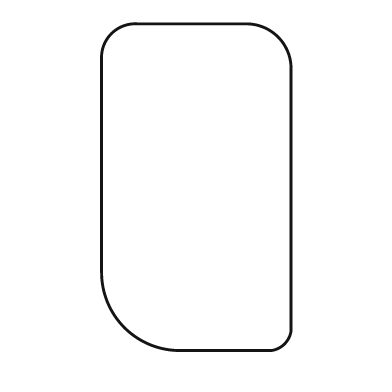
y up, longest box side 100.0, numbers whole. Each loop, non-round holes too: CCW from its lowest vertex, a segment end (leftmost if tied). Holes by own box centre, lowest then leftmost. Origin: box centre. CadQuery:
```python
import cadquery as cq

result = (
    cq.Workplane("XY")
    .moveTo(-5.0, -50.0)
    .lineTo(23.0, -50.0)
    .threePointArc((27.0, -48.0), (29.0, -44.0))
    .lineTo(29.0, 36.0)
    .threePointArc((25.0, 46.0), (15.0, 50.0))
    .lineTo(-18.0, 50.0)
    .threePointArc((-26.0, 47.0), (-29.0, 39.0))
    .lineTo(-29.0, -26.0)
    .threePointArc((-22.0, -43.0), (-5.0, -50.0))
    .close()
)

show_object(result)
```